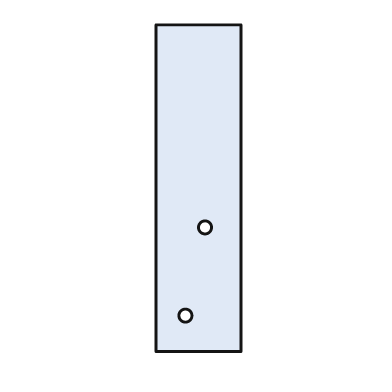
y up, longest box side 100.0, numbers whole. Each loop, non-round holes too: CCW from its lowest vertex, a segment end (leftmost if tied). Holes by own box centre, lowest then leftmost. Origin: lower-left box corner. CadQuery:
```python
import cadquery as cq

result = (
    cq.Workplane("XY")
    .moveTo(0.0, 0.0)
    .lineTo(26.0, 0.0)
    .lineTo(26.0, 100.0)
    .lineTo(0.0, 100.0)
    .close()
    .moveTo(9.0, 11.0)
    .circle(2.0)
    .moveTo(15.0, 38.0)
    .circle(2.0)
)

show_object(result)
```